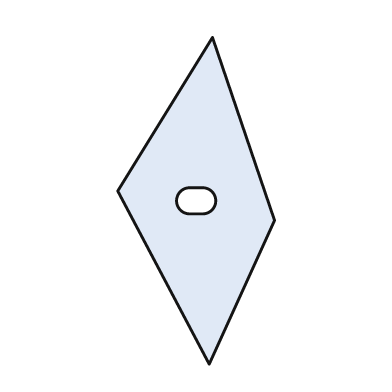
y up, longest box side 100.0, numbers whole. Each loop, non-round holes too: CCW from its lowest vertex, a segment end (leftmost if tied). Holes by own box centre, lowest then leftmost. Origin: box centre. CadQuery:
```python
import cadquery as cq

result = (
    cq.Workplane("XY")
    .moveTo(4.0, -50.0)
    .lineTo(24.0, -6.0)
    .lineTo(5.0, 50.0)
    .lineTo(-24.0, 3.0)
    .close()
    .moveTo(-2.0, -4.0)
    .lineTo(2.0, -4.0)
    .threePointArc((6.0, 0.0), (2.0, 4.0))
    .lineTo(-2.0, 4.0)
    .threePointArc((-6.0, 0.0), (-2.0, -4.0))
    .close()
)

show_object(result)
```